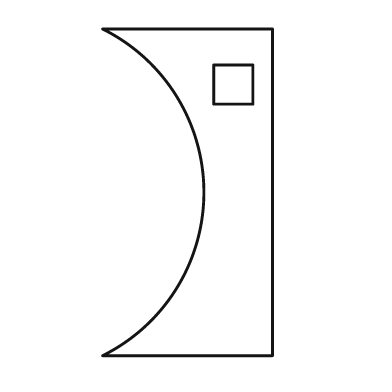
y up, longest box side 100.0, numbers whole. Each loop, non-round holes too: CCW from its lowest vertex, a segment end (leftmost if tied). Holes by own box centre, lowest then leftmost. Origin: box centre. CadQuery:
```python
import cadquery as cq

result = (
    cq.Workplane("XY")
    .moveTo(-26.0, -50.0)
    .lineTo(26.0, -50.0)
    .lineTo(26.0, 50.0)
    .lineTo(-26.0, 50.0)
    .threePointArc((5.0, 0.0), (-26.0, -50.0))
    .close()
    .moveTo(8.0, 27.0)
    .lineTo(20.0, 27.0)
    .lineTo(20.0, 39.0)
    .lineTo(8.0, 39.0)
    .close()
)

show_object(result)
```